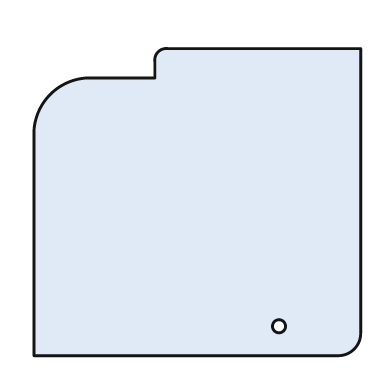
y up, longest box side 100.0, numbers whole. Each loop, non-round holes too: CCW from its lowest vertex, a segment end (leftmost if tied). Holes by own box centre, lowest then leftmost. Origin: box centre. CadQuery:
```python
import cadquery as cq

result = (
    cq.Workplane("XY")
    .moveTo(-50.0, -47.0)
    .lineTo(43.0, -47.0)
    .threePointArc((48.0, -45.0), (50.0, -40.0))
    .lineTo(50.0, 47.0)
    .lineTo(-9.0, 47.0)
    .threePointArc((-12.0, 46.0), (-13.0, 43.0))
    .lineTo(-13.0, 38.0)
    .lineTo(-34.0, 38.0)
    .threePointArc((-45.0, 33.0), (-50.0, 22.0))
    .close()
    .moveTo(25.0, -38.0)
    .circle(2.0)
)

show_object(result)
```